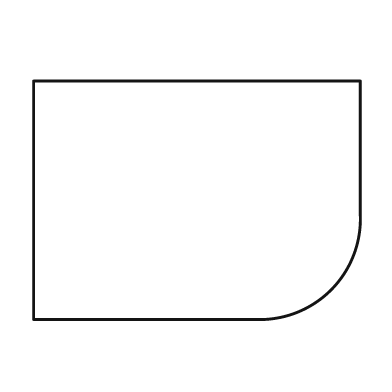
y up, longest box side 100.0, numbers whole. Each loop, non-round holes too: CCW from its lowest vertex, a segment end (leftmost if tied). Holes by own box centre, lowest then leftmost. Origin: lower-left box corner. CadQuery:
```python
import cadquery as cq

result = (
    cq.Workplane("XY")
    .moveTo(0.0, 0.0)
    .lineTo(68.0, 0.0)
    .threePointArc((91.0, 9.0), (100.0, 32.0))
    .lineTo(100.0, 73.0)
    .lineTo(0.0, 73.0)
    .close()
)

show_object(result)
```